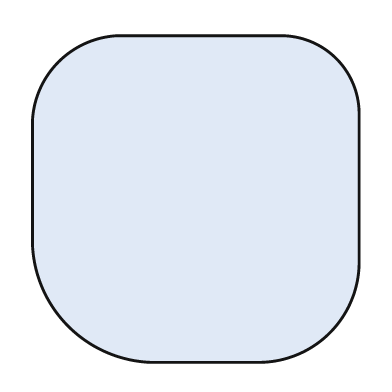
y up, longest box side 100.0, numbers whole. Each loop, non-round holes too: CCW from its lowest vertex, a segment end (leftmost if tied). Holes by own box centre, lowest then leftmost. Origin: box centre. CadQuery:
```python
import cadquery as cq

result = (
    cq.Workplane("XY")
    .moveTo(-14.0, -50.0)
    .lineTo(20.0, -50.0)
    .threePointArc((41.0, -41.0), (50.0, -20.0))
    .lineTo(50.0, 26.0)
    .threePointArc((43.0, 43.0), (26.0, 50.0))
    .lineTo(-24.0, 50.0)
    .threePointArc((-42.0, 42.0), (-50.0, 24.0))
    .lineTo(-50.0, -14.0)
    .threePointArc((-39.0, -39.0), (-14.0, -50.0))
    .close()
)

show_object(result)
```